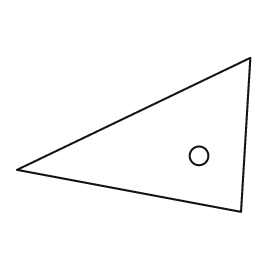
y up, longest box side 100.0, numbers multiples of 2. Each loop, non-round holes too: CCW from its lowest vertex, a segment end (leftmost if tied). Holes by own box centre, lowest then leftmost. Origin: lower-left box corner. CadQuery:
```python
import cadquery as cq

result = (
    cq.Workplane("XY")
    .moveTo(96.0, 0.0)
    .lineTo(100.0, 66.0)
    .lineTo(0.0, 18.0)
    .close()
    .moveTo(78.0, 24.0)
    .circle(4.0)
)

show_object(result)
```